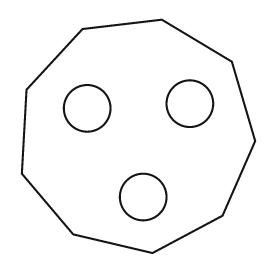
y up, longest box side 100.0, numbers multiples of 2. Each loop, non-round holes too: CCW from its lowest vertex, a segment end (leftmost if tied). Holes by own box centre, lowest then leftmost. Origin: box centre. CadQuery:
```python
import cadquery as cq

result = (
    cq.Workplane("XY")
    .moveTo(6.0, -50.0)
    .lineTo(36.0, -34.0)
    .lineTo(50.0, -2.0)
    .lineTo(40.0, 32.0)
    .lineTo(10.0, 50.0)
    .lineTo(-24.0, 46.0)
    .lineTo(-48.0, 20.0)
    .lineTo(-50.0, -16.0)
    .lineTo(-28.0, -42.0)
    .close()
    .moveTo(2.0, -26.0)
    .circle(10.0)
    .moveTo(-22.0, 12.0)
    .circle(10.0)
    .moveTo(22.0, 14.0)
    .circle(10.0)
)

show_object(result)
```